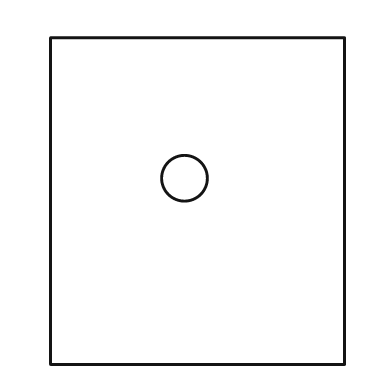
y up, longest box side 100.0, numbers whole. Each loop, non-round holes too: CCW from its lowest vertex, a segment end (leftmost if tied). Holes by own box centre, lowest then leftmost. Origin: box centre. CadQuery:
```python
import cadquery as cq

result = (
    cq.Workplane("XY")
    .moveTo(-45.0, -50.0)
    .lineTo(45.0, -50.0)
    .lineTo(45.0, 50.0)
    .lineTo(-45.0, 50.0)
    .close()
    .moveTo(-4.0, 7.0)
    .circle(7.0)
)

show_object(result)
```